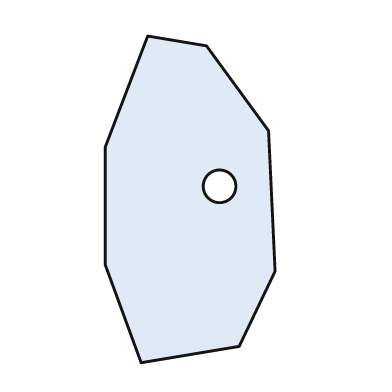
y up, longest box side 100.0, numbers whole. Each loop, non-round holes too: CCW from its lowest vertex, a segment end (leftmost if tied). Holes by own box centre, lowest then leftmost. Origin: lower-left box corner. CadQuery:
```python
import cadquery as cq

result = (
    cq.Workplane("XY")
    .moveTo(11.0, 0.0)
    .lineTo(41.0, 5.0)
    .lineTo(52.0, 28.0)
    .lineTo(50.0, 71.0)
    .lineTo(31.0, 97.0)
    .lineTo(13.0, 100.0)
    .lineTo(0.0, 66.0)
    .lineTo(0.0, 30.0)
    .close()
    .moveTo(35.0, 54.0)
    .circle(5.0)
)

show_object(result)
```